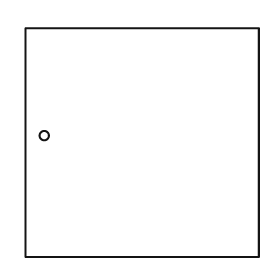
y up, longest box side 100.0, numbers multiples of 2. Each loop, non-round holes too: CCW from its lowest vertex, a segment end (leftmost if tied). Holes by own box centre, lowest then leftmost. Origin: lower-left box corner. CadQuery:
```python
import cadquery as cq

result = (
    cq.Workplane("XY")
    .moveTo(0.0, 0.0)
    .lineTo(100.0, 0.0)
    .lineTo(100.0, 98.0)
    .lineTo(0.0, 98.0)
    .close()
    .moveTo(8.0, 52.0)
    .circle(2.0)
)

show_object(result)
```